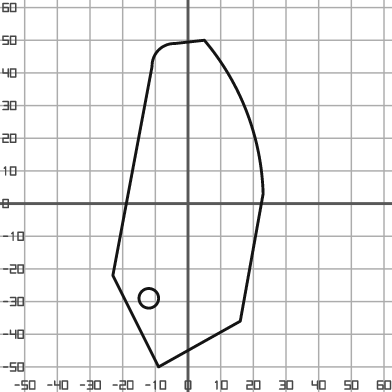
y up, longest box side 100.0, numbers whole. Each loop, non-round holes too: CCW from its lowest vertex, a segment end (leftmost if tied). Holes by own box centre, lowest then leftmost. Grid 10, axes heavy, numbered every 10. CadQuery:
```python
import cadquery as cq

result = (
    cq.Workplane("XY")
    .moveTo(-9.0, -50.0)
    .lineTo(16.0, -36.0)
    .lineTo(23.0, 3.0)
    .threePointArc((18.0, 28.0), (5.0, 50.0))
    .lineTo(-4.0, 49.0)
    .threePointArc((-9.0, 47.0), (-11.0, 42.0))
    .lineTo(-23.0, -22.0)
    .close()
    .moveTo(-12.0, -29.0)
    .circle(3.0)
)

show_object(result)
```